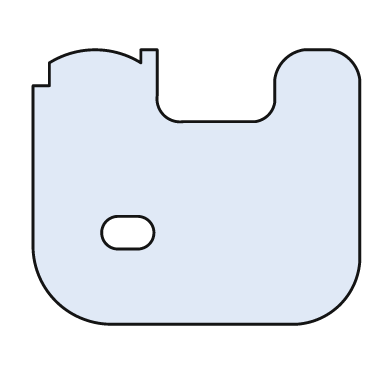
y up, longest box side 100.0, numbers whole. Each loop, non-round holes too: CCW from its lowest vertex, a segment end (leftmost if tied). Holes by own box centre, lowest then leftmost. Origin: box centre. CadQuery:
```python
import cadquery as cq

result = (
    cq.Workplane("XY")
    .moveTo(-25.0, -42.0)
    .lineTo(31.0, -42.0)
    .threePointArc((44.0, -36.0), (50.0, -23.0))
    .lineTo(50.0, 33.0)
    .threePointArc((47.0, 39.0), (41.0, 42.0))
    .lineTo(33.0, 42.0)
    .threePointArc((27.0, 39.0), (24.0, 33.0))
    .lineTo(24.0, 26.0)
    .threePointArc((22.0, 22.0), (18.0, 20.0))
    .lineTo(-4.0, 20.0)
    .threePointArc((-10.0, 22.0), (-12.0, 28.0))
    .lineTo(-12.0, 42.0)
    .lineTo(-17.0, 42.0)
    .lineTo(-17.0, 38.0)
    .threePointArc((-31.0, 42.0), (-45.0, 38.0))
    .lineTo(-45.0, 31.0)
    .lineTo(-50.0, 31.0)
    .lineTo(-50.0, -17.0)
    .threePointArc((-43.0, -35.0), (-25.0, -42.0))
    .close()
    .moveTo(-24.0, -19.0)
    .lineTo(-18.0, -19.0)
    .threePointArc((-13.0, -14.0), (-18.0, -9.0))
    .lineTo(-24.0, -9.0)
    .threePointArc((-29.0, -14.0), (-24.0, -19.0))
    .close()
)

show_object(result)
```